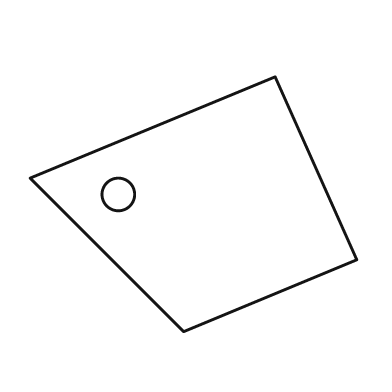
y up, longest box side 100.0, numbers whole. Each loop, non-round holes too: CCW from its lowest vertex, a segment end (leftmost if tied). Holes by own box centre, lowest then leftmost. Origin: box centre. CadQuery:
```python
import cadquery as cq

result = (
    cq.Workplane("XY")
    .moveTo(-3.0, -39.0)
    .lineTo(50.0, -17.0)
    .lineTo(25.0, 39.0)
    .lineTo(-50.0, 8.0)
    .close()
    .moveTo(-23.0, 3.0)
    .circle(5.0)
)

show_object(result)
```